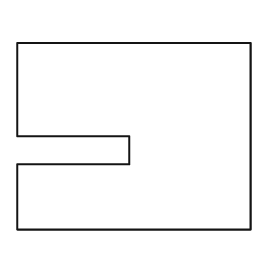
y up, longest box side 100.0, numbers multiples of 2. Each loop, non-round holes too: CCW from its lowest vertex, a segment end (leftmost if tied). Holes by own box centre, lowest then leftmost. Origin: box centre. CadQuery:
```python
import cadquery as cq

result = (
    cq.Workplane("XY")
    .moveTo(-50.0, -40.0)
    .lineTo(50.0, -40.0)
    .lineTo(50.0, 40.0)
    .lineTo(-50.0, 40.0)
    .lineTo(-50.0, 0.0)
    .lineTo(-2.0, 0.0)
    .lineTo(-2.0, -12.0)
    .lineTo(-50.0, -12.0)
    .close()
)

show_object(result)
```